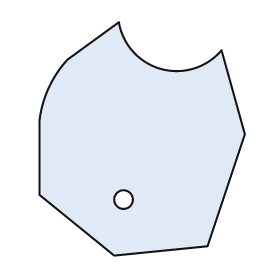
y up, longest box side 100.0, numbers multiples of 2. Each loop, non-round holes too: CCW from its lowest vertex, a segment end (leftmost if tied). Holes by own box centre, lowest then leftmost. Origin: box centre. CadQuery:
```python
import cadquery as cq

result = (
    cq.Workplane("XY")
    .moveTo(-12.0, -50.0)
    .lineTo(28.0, -46.0)
    .lineTo(44.0, 2.0)
    .lineTo(34.0, 38.0)
    .threePointArc((8.0, 30.0), (-10.0, 50.0))
    .lineTo(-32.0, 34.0)
    .threePointArc((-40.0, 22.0), (-44.0, 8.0))
    .lineTo(-44.0, -24.0)
    .close()
    .moveTo(-8.0, -26.0)
    .circle(4.0)
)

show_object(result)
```